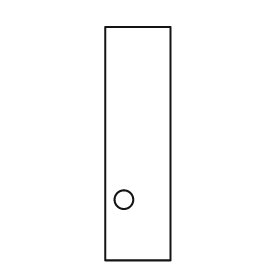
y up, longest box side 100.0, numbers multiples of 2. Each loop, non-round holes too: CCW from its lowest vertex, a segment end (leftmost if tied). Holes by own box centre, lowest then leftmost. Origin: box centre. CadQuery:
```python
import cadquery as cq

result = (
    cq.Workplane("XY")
    .moveTo(-14.0, -50.0)
    .lineTo(14.0, -50.0)
    .lineTo(14.0, 50.0)
    .lineTo(-14.0, 50.0)
    .close()
    .moveTo(-6.0, -24.0)
    .circle(4.0)
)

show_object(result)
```